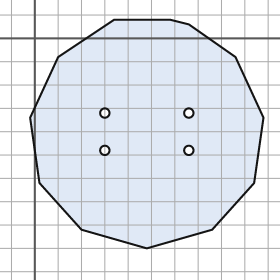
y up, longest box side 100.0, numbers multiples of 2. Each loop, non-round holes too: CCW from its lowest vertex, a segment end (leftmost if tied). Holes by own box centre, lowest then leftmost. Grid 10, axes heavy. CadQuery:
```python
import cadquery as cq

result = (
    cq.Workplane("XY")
    .moveTo(48.0, -90.0)
    .lineTo(76.0, -82.0)
    .lineTo(94.0, -62.0)
    .lineTo(98.0, -34.0)
    .lineTo(86.0, -8.0)
    .lineTo(66.0, 6.0)
    .lineTo(58.0, 8.0)
    .lineTo(34.0, 8.0)
    .lineTo(10.0, -8.0)
    .lineTo(-2.0, -34.0)
    .lineTo(2.0, -62.0)
    .lineTo(20.0, -82.0)
    .close()
    .moveTo(30.0, -48.0)
    .circle(2.0)
    .moveTo(66.0, -48.0)
    .circle(2.0)
    .moveTo(30.0, -32.0)
    .circle(2.0)
    .moveTo(66.0, -32.0)
    .circle(2.0)
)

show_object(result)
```